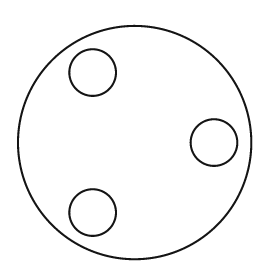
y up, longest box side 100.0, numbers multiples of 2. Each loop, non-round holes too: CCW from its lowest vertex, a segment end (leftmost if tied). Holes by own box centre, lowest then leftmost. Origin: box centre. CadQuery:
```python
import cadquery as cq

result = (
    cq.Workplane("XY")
    .moveTo(0.0, 0.0)
    .circle(50.0)
    .moveTo(-18.0, -30.0)
    .circle(10.0)
    .moveTo(34.0, 0.0)
    .circle(10.0)
    .moveTo(-18.0, 30.0)
    .circle(10.0)
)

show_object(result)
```